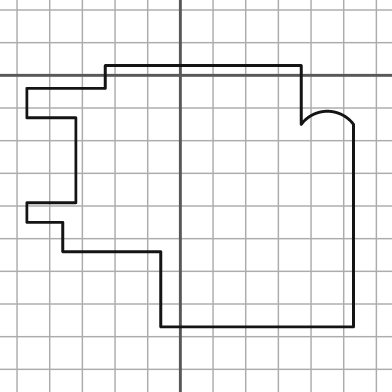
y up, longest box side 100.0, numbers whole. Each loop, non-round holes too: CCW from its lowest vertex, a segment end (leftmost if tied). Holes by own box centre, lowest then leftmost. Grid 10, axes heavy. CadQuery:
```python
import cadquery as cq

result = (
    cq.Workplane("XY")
    .moveTo(-6.0, -77.0)
    .lineTo(53.0, -77.0)
    .lineTo(53.0, -15.0)
    .threePointArc((45.0, -11.0), (37.0, -15.0))
    .lineTo(37.0, 3.0)
    .lineTo(-23.0, 3.0)
    .lineTo(-23.0, -4.0)
    .lineTo(-47.0, -4.0)
    .lineTo(-47.0, -13.0)
    .lineTo(-32.0, -13.0)
    .lineTo(-32.0, -39.0)
    .lineTo(-47.0, -39.0)
    .lineTo(-47.0, -45.0)
    .lineTo(-36.0, -45.0)
    .lineTo(-36.0, -54.0)
    .lineTo(-6.0, -54.0)
    .close()
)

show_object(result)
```